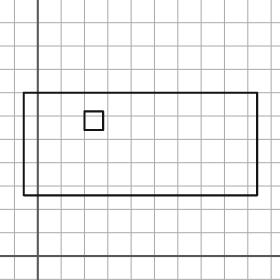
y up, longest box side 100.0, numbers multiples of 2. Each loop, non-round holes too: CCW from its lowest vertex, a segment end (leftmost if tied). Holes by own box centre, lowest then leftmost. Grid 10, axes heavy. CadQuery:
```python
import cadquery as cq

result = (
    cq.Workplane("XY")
    .moveTo(-6.0, 26.0)
    .lineTo(94.0, 26.0)
    .lineTo(94.0, 70.0)
    .lineTo(-6.0, 70.0)
    .close()
    .moveTo(20.0, 54.0)
    .lineTo(28.0, 54.0)
    .lineTo(28.0, 62.0)
    .lineTo(20.0, 62.0)
    .close()
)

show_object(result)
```